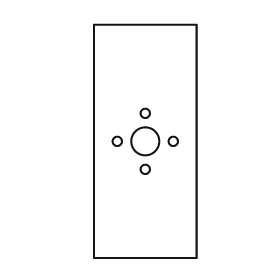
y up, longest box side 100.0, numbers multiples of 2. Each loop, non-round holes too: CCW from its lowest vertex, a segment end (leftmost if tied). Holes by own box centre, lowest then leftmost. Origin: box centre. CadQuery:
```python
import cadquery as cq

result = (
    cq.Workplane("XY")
    .moveTo(-22.0, -50.0)
    .lineTo(22.0, -50.0)
    .lineTo(22.0, 50.0)
    .lineTo(-22.0, 50.0)
    .close()
    .moveTo(0.0, -12.0)
    .circle(2.0)
    .moveTo(-12.0, 0.0)
    .circle(2.0)
    .moveTo(0.0, 0.0)
    .circle(6.0)
    .moveTo(12.0, 0.0)
    .circle(2.0)
    .moveTo(0.0, 12.0)
    .circle(2.0)
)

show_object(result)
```